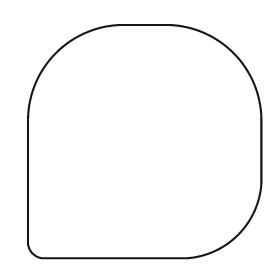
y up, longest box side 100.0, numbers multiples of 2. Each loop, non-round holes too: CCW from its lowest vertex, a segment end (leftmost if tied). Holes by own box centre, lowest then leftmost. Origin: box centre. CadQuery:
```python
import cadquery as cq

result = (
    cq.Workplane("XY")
    .moveTo(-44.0, -50.0)
    .lineTo(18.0, -50.0)
    .threePointArc((40.0, -40.0), (50.0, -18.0))
    .lineTo(50.0, 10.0)
    .threePointArc((38.0, 38.0), (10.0, 50.0))
    .lineTo(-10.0, 50.0)
    .threePointArc((-38.0, 38.0), (-50.0, 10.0))
    .lineTo(-50.0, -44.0)
    .threePointArc((-48.0, -48.0), (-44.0, -50.0))
    .close()
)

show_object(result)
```